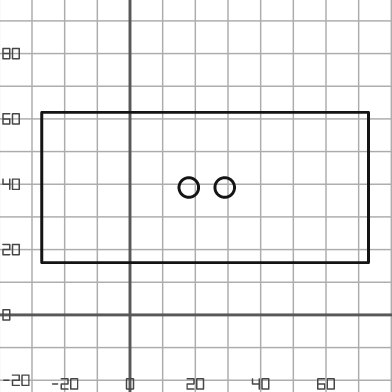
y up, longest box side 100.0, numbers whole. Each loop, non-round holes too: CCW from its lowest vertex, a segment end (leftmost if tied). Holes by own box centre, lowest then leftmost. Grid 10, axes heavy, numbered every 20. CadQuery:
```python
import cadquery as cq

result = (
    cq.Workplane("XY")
    .moveTo(-27.0, 16.0)
    .lineTo(73.0, 16.0)
    .lineTo(73.0, 62.0)
    .lineTo(-27.0, 62.0)
    .close()
    .moveTo(18.0, 39.0)
    .circle(3.0)
    .moveTo(29.0, 39.0)
    .circle(3.0)
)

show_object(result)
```